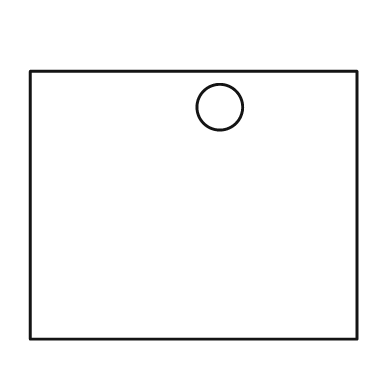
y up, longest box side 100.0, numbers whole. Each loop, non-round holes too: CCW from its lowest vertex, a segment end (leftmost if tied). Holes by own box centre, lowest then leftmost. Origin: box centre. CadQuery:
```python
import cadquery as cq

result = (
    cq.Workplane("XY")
    .moveTo(-50.0, -41.0)
    .lineTo(50.0, -41.0)
    .lineTo(50.0, 41.0)
    .lineTo(-50.0, 41.0)
    .close()
    .moveTo(8.0, 30.0)
    .circle(7.0)
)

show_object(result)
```